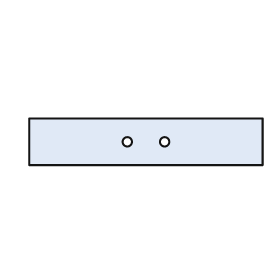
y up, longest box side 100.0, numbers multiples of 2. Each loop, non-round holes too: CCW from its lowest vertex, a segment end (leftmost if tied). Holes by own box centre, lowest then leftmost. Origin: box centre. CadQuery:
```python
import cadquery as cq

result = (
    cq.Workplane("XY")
    .moveTo(-50.0, -10.0)
    .lineTo(50.0, -10.0)
    .lineTo(50.0, 10.0)
    .lineTo(-50.0, 10.0)
    .close()
    .moveTo(-8.0, 0.0)
    .circle(2.0)
    .moveTo(8.0, 0.0)
    .circle(2.0)
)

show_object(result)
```